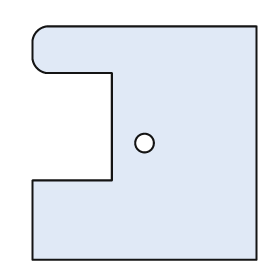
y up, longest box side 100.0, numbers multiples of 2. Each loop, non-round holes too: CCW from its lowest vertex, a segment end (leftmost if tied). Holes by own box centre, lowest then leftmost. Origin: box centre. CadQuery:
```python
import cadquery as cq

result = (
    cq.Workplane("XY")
    .moveTo(-48.0, -50.0)
    .lineTo(48.0, -50.0)
    .lineTo(48.0, 50.0)
    .lineTo(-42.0, 50.0)
    .threePointArc((-46.0, 48.0), (-48.0, 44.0))
    .lineTo(-48.0, 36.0)
    .threePointArc((-46.0, 32.0), (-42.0, 30.0))
    .lineTo(-14.0, 30.0)
    .lineTo(-14.0, -16.0)
    .lineTo(-48.0, -16.0)
    .close()
    .moveTo(0.0, 0.0)
    .circle(4.0)
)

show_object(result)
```